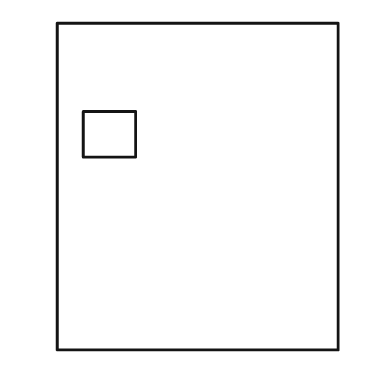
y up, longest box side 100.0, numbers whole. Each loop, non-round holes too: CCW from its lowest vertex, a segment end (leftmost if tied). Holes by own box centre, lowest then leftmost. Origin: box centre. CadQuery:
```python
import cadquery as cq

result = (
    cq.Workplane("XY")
    .moveTo(-43.0, -50.0)
    .lineTo(43.0, -50.0)
    .lineTo(43.0, 50.0)
    .lineTo(-43.0, 50.0)
    .close()
    .moveTo(-35.0, 9.0)
    .lineTo(-19.0, 9.0)
    .lineTo(-19.0, 23.0)
    .lineTo(-35.0, 23.0)
    .close()
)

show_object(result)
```